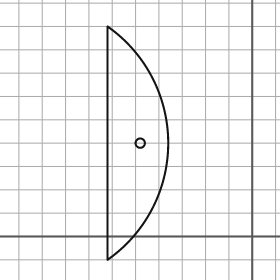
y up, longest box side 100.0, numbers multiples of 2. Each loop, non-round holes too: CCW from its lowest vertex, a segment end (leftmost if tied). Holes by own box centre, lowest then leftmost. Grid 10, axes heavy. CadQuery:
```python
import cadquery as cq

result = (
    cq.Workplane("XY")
    .moveTo(-62.0, -10.0)
    .threePointArc((-36.0, 40.0), (-62.0, 90.0))
    .close()
    .moveTo(-48.0, 40.0)
    .circle(2.0)
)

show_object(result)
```